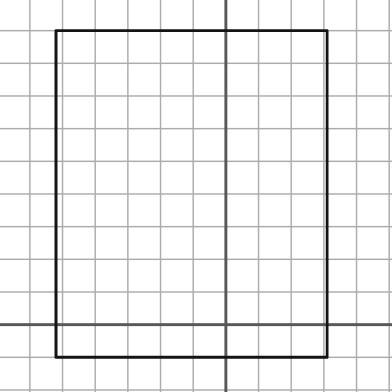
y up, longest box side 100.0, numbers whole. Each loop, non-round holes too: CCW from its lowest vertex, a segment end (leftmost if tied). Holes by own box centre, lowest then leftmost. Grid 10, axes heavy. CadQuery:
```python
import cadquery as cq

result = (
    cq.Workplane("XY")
    .moveTo(-52.0, -10.0)
    .lineTo(31.0, -10.0)
    .lineTo(31.0, 90.0)
    .lineTo(-52.0, 90.0)
    .close()
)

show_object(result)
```